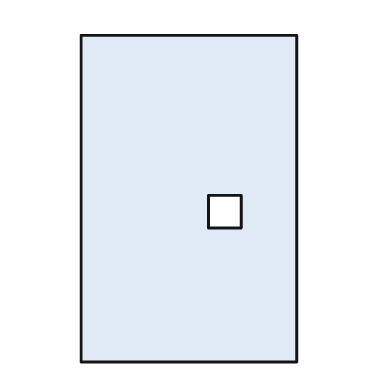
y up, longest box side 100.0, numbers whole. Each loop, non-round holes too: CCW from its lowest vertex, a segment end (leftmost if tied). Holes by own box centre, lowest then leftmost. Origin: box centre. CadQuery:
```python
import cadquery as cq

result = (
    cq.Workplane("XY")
    .moveTo(-33.0, -50.0)
    .lineTo(33.0, -50.0)
    .lineTo(33.0, 50.0)
    .lineTo(-33.0, 50.0)
    .close()
    .moveTo(6.0, -9.0)
    .lineTo(16.0, -9.0)
    .lineTo(16.0, 1.0)
    .lineTo(6.0, 1.0)
    .close()
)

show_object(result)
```